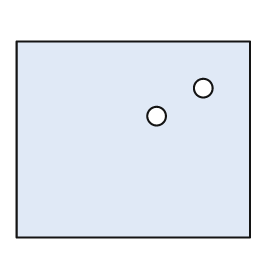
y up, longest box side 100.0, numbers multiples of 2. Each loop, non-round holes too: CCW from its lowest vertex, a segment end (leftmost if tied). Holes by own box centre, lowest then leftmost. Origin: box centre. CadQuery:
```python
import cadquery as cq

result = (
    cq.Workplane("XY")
    .moveTo(-50.0, -42.0)
    .lineTo(50.0, -42.0)
    .lineTo(50.0, 42.0)
    .lineTo(-50.0, 42.0)
    .close()
    .moveTo(10.0, 10.0)
    .circle(4.0)
    .moveTo(30.0, 22.0)
    .circle(4.0)
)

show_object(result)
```